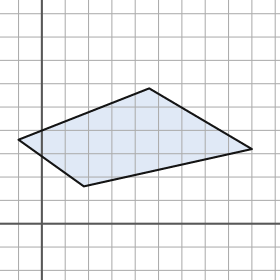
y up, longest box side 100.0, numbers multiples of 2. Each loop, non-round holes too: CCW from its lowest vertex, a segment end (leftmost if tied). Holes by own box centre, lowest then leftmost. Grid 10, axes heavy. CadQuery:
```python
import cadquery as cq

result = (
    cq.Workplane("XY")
    .moveTo(18.0, 16.0)
    .lineTo(90.0, 32.0)
    .lineTo(46.0, 58.0)
    .lineTo(-10.0, 36.0)
    .close()
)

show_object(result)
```